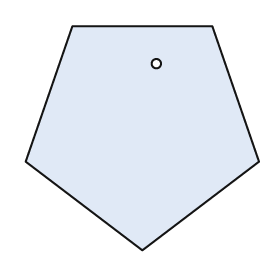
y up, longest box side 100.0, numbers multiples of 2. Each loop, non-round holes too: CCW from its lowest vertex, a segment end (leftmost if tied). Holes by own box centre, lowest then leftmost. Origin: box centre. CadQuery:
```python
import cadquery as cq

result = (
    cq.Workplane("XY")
    .moveTo(0.0, -48.0)
    .lineTo(50.0, -10.0)
    .lineTo(30.0, 48.0)
    .lineTo(-30.0, 48.0)
    .lineTo(-50.0, -10.0)
    .close()
    .moveTo(6.0, 32.0)
    .circle(2.0)
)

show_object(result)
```